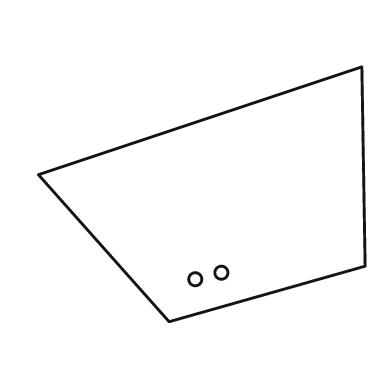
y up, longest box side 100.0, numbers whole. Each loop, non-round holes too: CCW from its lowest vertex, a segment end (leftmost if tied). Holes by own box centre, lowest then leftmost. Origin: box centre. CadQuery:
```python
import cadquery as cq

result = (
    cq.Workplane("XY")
    .moveTo(-10.0, -39.0)
    .lineTo(50.0, -22.0)
    .lineTo(49.0, 39.0)
    .lineTo(-50.0, 6.0)
    .close()
    .moveTo(-2.0, -26.0)
    .circle(2.0)
    .moveTo(6.0, -24.0)
    .circle(2.0)
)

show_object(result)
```